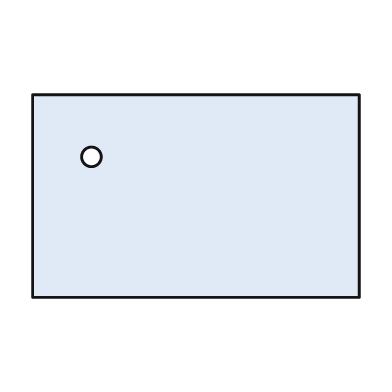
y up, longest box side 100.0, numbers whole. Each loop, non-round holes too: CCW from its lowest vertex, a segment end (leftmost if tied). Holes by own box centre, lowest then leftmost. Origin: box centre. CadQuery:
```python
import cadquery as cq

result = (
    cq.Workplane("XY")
    .moveTo(-50.0, -31.0)
    .lineTo(50.0, -31.0)
    .lineTo(50.0, 31.0)
    .lineTo(-50.0, 31.0)
    .close()
    .moveTo(-32.0, 12.0)
    .circle(3.0)
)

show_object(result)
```